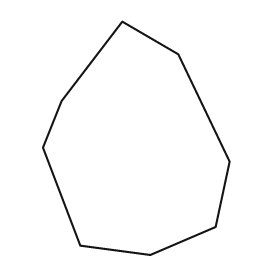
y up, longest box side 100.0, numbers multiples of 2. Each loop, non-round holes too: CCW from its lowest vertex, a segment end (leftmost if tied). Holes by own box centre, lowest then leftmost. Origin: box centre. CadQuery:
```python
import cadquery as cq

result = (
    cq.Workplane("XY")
    .moveTo(6.0, -50.0)
    .lineTo(34.0, -38.0)
    .lineTo(40.0, -10.0)
    .lineTo(18.0, 36.0)
    .lineTo(-6.0, 50.0)
    .lineTo(-32.0, 16.0)
    .lineTo(-40.0, -4.0)
    .lineTo(-24.0, -46.0)
    .close()
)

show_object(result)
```